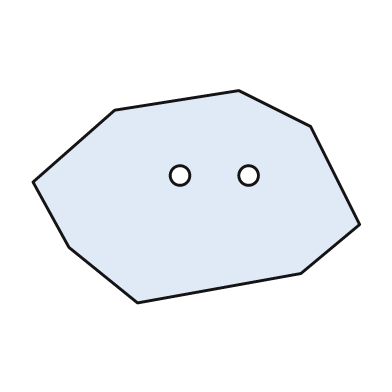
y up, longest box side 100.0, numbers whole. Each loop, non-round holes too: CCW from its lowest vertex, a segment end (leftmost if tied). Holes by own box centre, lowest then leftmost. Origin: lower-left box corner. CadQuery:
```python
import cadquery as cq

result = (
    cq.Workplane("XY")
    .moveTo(32.0, 0.0)
    .lineTo(82.0, 9.0)
    .lineTo(100.0, 24.0)
    .lineTo(85.0, 54.0)
    .lineTo(63.0, 65.0)
    .lineTo(25.0, 59.0)
    .lineTo(0.0, 37.0)
    .lineTo(11.0, 17.0)
    .close()
    .moveTo(45.0, 39.0)
    .circle(3.0)
    .moveTo(66.0, 39.0)
    .circle(3.0)
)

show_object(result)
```